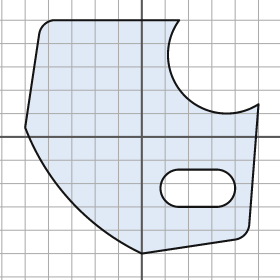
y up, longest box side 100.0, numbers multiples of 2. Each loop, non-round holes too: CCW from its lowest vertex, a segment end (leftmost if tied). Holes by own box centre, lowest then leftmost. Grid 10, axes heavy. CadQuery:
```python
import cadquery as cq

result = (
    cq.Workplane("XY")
    .moveTo(0.0, -50.0)
    .lineTo(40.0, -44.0)
    .threePointArc((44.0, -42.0), (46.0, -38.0))
    .lineTo(50.0, 14.0)
    .threePointArc((18.0, 18.0), (16.0, 50.0))
    .lineTo(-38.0, 50.0)
    .threePointArc((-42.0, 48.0), (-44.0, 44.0))
    .lineTo(-50.0, 4.0)
    .threePointArc((-30.0, -28.0), (0.0, -50.0))
    .close()
    .moveTo(16.0, -30.0)
    .lineTo(32.0, -30.0)
    .threePointArc((40.0, -22.0), (32.0, -14.0))
    .lineTo(16.0, -14.0)
    .threePointArc((8.0, -22.0), (16.0, -30.0))
    .close()
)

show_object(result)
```